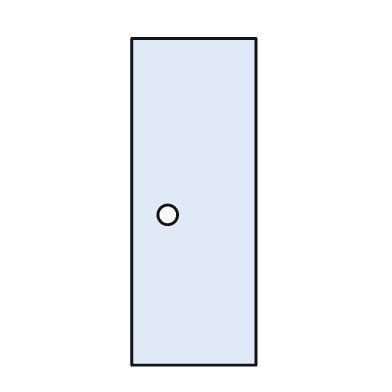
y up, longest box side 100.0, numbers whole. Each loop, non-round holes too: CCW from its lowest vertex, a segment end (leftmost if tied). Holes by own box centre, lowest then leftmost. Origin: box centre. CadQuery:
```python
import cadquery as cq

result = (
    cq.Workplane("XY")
    .moveTo(-19.0, -50.0)
    .lineTo(19.0, -50.0)
    .lineTo(19.0, 50.0)
    .lineTo(-19.0, 50.0)
    .close()
    .moveTo(-8.0, -4.0)
    .circle(3.0)
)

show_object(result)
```